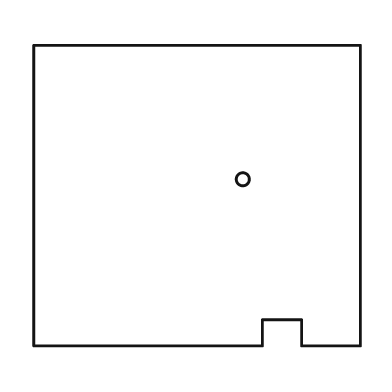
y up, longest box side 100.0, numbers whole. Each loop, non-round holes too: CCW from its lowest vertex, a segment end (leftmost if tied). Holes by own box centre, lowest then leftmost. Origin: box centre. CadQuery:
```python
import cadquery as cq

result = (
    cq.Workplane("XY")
    .moveTo(-50.0, -46.0)
    .lineTo(20.0, -46.0)
    .lineTo(20.0, -38.0)
    .lineTo(32.0, -38.0)
    .lineTo(32.0, -46.0)
    .lineTo(50.0, -46.0)
    .lineTo(50.0, 46.0)
    .lineTo(-50.0, 46.0)
    .close()
    .moveTo(14.0, 5.0)
    .circle(2.0)
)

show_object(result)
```